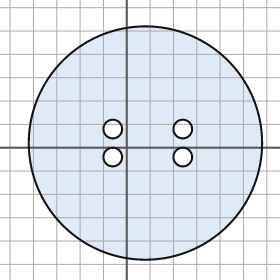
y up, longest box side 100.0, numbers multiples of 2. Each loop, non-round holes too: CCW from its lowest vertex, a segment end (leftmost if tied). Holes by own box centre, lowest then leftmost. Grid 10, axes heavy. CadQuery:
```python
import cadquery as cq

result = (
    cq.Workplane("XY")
    .moveTo(8.0, 2.0)
    .circle(50.0)
    .moveTo(-6.0, -4.0)
    .circle(4.0)
    .moveTo(24.0, -4.0)
    .circle(4.0)
    .moveTo(-6.0, 8.0)
    .circle(4.0)
    .moveTo(24.0, 8.0)
    .circle(4.0)
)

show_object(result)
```